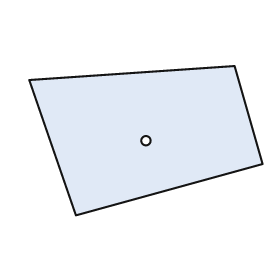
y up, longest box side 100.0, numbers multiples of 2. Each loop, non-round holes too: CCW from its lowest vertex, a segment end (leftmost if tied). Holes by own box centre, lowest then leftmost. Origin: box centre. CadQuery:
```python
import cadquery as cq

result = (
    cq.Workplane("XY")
    .moveTo(-30.0, -32.0)
    .lineTo(50.0, -10.0)
    .lineTo(38.0, 32.0)
    .lineTo(-50.0, 26.0)
    .close()
    .moveTo(0.0, 0.0)
    .circle(2.0)
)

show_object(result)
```